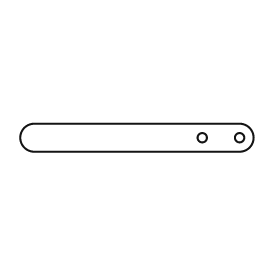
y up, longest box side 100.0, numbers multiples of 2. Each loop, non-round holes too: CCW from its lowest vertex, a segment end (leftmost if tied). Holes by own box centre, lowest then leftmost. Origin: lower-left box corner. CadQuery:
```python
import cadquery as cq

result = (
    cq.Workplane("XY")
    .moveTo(6.0, 0.0)
    .lineTo(94.0, 0.0)
    .threePointArc((100.0, 6.0), (94.0, 12.0))
    .lineTo(6.0, 12.0)
    .threePointArc((0.0, 6.0), (6.0, 0.0))
    .close()
    .moveTo(78.0, 6.0)
    .circle(2.0)
    .moveTo(94.0, 6.0)
    .circle(2.0)
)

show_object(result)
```